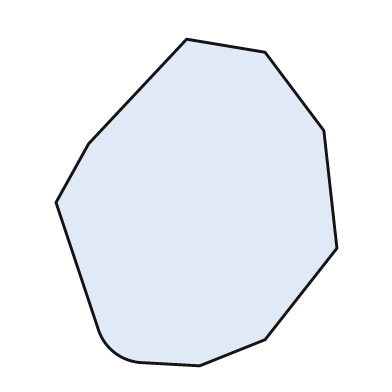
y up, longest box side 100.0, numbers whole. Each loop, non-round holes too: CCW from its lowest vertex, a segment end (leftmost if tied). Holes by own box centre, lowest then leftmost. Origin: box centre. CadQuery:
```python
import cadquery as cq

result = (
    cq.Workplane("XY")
    .moveTo(1.0, -50.0)
    .lineTo(21.0, -42.0)
    .lineTo(43.0, -14.0)
    .lineTo(39.0, 22.0)
    .lineTo(21.0, 46.0)
    .lineTo(-3.0, 50.0)
    .lineTo(-33.0, 18.0)
    .lineTo(-43.0, 0.0)
    .lineTo(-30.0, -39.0)
    .threePointArc((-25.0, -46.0), (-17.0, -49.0))
    .close()
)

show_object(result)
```